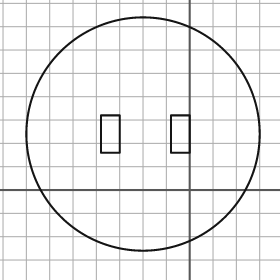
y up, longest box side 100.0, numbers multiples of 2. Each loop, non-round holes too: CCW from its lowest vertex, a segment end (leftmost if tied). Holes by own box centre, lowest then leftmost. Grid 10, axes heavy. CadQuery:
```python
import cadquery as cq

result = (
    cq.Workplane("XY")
    .moveTo(-20.0, 24.0)
    .circle(50.0)
    .moveTo(-38.0, 16.0)
    .lineTo(-30.0, 16.0)
    .lineTo(-30.0, 32.0)
    .lineTo(-38.0, 32.0)
    .close()
    .moveTo(-8.0, 16.0)
    .lineTo(0.0, 16.0)
    .lineTo(0.0, 32.0)
    .lineTo(-8.0, 32.0)
    .close()
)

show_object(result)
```